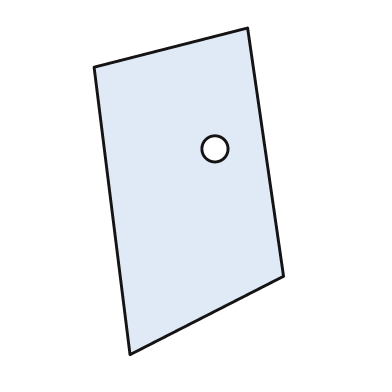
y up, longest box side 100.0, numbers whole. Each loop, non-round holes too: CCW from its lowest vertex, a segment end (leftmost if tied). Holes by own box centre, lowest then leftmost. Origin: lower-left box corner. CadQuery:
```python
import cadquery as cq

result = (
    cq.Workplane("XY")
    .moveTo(11.0, 0.0)
    .lineTo(58.0, 24.0)
    .lineTo(47.0, 100.0)
    .lineTo(0.0, 88.0)
    .close()
    .moveTo(37.0, 63.0)
    .circle(4.0)
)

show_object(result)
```